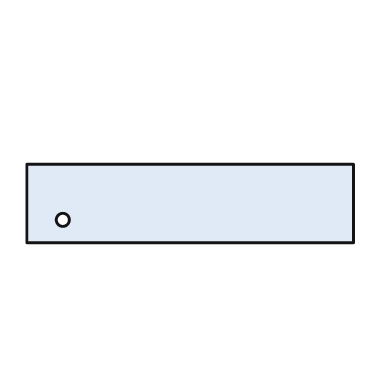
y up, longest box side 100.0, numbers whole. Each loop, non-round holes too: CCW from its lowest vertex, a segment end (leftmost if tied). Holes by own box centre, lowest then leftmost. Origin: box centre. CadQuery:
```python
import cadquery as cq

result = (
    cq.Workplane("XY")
    .moveTo(-50.0, -12.0)
    .lineTo(50.0, -12.0)
    .lineTo(50.0, 12.0)
    .lineTo(-50.0, 12.0)
    .close()
    .moveTo(-39.0, -5.0)
    .circle(2.0)
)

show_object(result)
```